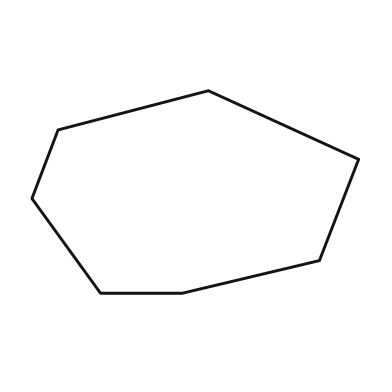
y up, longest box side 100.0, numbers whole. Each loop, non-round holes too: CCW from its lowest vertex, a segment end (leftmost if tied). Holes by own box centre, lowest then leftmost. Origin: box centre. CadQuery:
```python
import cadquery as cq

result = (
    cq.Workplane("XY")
    .moveTo(-29.0, -31.0)
    .lineTo(-4.0, -31.0)
    .lineTo(38.0, -21.0)
    .lineTo(50.0, 10.0)
    .lineTo(4.0, 31.0)
    .lineTo(-42.0, 19.0)
    .lineTo(-50.0, -2.0)
    .close()
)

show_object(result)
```